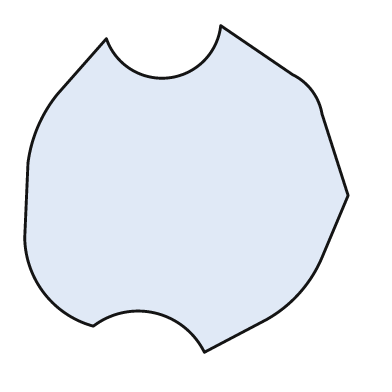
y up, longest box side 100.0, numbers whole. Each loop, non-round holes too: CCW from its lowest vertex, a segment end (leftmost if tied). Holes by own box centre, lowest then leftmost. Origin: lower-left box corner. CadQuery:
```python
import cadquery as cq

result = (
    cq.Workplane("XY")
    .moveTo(55.0, 0.0)
    .lineTo(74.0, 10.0)
    .threePointArc((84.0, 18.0), (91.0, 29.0))
    .lineTo(99.0, 48.0)
    .lineTo(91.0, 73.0)
    .threePointArc((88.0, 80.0), (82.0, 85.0))
    .lineTo(60.0, 100.0)
    .threePointArc((44.0, 84.0), (25.0, 96.0))
    .lineTo(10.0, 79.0)
    .threePointArc((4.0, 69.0), (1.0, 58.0))
    .lineTo(0.0, 35.0)
    .threePointArc((6.0, 18.0), (21.0, 8.0))
    .threePointArc((40.0, 12.0), (55.0, 0.0))
    .close()
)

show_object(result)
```